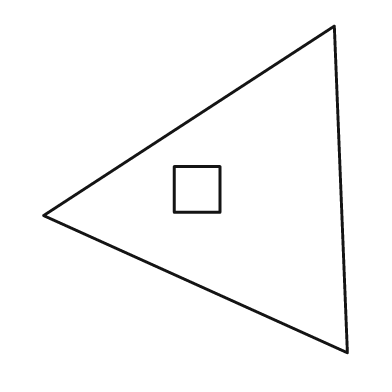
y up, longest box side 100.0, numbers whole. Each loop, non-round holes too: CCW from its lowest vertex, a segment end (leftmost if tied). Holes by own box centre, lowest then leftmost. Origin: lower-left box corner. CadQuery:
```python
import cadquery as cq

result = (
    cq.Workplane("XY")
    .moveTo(93.0, 0.0)
    .lineTo(89.0, 100.0)
    .lineTo(0.0, 42.0)
    .close()
    .moveTo(40.0, 43.0)
    .lineTo(54.0, 43.0)
    .lineTo(54.0, 57.0)
    .lineTo(40.0, 57.0)
    .close()
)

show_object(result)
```